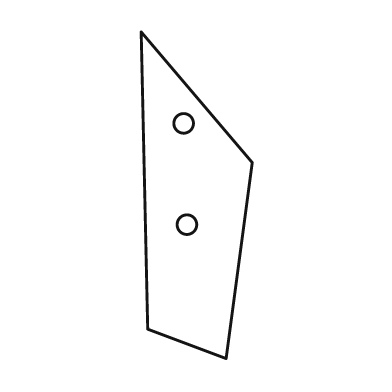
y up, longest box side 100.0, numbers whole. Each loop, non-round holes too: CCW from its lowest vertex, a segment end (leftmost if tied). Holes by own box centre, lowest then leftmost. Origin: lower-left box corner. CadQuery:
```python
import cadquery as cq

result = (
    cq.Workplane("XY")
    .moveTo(26.0, 0.0)
    .lineTo(34.0, 60.0)
    .lineTo(0.0, 100.0)
    .lineTo(2.0, 9.0)
    .close()
    .moveTo(14.0, 41.0)
    .circle(3.0)
    .moveTo(13.0, 72.0)
    .circle(3.0)
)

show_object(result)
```